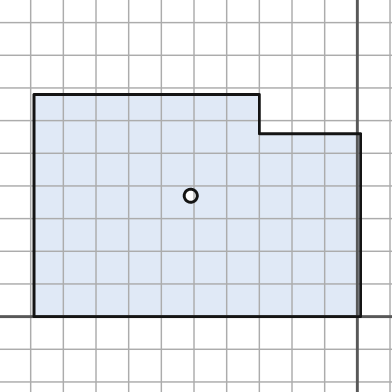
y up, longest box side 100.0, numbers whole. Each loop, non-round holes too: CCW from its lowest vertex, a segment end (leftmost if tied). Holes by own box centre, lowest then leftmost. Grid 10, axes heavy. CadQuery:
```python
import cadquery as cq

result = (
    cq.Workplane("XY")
    .moveTo(-99.0, 0.0)
    .lineTo(1.0, 0.0)
    .lineTo(1.0, 56.0)
    .lineTo(-30.0, 56.0)
    .lineTo(-30.0, 68.0)
    .lineTo(-99.0, 68.0)
    .close()
    .moveTo(-51.0, 37.0)
    .circle(2.0)
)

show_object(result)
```